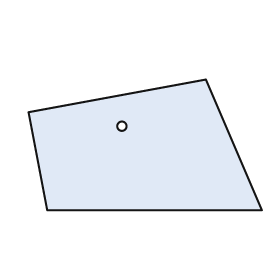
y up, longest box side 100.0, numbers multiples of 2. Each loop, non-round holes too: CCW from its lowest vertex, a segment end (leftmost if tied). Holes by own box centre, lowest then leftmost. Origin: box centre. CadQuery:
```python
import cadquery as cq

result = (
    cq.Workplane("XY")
    .moveTo(-42.0, -28.0)
    .lineTo(50.0, -28.0)
    .lineTo(26.0, 28.0)
    .lineTo(-50.0, 14.0)
    .close()
    .moveTo(-10.0, 8.0)
    .circle(2.0)
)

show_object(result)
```